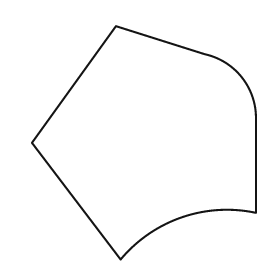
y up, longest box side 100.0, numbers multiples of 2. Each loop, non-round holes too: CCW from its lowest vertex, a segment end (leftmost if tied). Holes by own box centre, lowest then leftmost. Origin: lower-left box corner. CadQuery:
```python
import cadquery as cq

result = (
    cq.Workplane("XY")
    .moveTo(38.0, 0.0)
    .threePointArc((64.0, 18.0), (96.0, 20.0))
    .lineTo(96.0, 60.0)
    .threePointArc((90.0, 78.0), (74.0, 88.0))
    .lineTo(36.0, 100.0)
    .lineTo(0.0, 50.0)
    .close()
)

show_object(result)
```